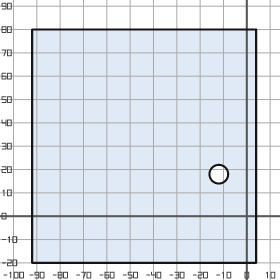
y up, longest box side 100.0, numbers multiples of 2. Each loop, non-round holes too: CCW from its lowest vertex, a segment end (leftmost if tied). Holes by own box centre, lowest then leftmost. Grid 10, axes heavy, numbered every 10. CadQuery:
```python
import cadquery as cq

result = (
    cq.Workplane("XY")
    .moveTo(-92.0, -20.0)
    .lineTo(4.0, -20.0)
    .lineTo(4.0, 80.0)
    .lineTo(-92.0, 80.0)
    .close()
    .moveTo(-12.0, 18.0)
    .circle(4.0)
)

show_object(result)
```